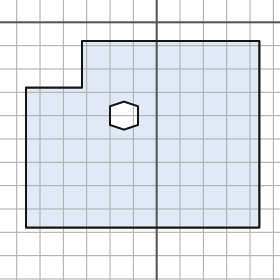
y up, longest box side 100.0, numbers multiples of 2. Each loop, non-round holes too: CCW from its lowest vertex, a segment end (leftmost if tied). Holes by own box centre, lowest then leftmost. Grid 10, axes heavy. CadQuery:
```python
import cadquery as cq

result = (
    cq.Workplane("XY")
    .moveTo(-56.0, -88.0)
    .lineTo(44.0, -88.0)
    .lineTo(44.0, -8.0)
    .lineTo(-32.0, -8.0)
    .lineTo(-32.0, -28.0)
    .lineTo(-56.0, -28.0)
    .close()
    .moveTo(-14.0, -46.0)
    .lineTo(-8.0, -44.0)
    .lineTo(-8.0, -36.0)
    .lineTo(-14.0, -34.0)
    .lineTo(-20.0, -36.0)
    .lineTo(-20.0, -44.0)
    .close()
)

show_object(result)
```